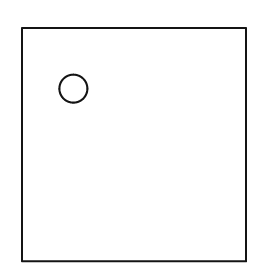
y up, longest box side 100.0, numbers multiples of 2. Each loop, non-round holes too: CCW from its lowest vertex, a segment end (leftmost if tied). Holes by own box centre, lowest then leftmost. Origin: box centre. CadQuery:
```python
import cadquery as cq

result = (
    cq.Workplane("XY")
    .moveTo(-48.0, -50.0)
    .lineTo(48.0, -50.0)
    .lineTo(48.0, 50.0)
    .lineTo(-48.0, 50.0)
    .close()
    .moveTo(-26.0, 24.0)
    .circle(6.0)
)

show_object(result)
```